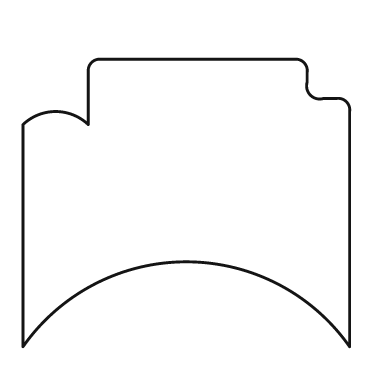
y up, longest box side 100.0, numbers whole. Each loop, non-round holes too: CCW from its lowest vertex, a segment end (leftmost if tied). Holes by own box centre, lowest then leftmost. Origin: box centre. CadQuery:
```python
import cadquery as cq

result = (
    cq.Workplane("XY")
    .moveTo(-50.0, -44.0)
    .threePointArc((0.0, -18.0), (50.0, -44.0))
    .lineTo(50.0, 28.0)
    .threePointArc((49.0, 31.0), (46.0, 32.0))
    .lineTo(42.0, 32.0)
    .threePointArc((38.0, 33.0), (37.0, 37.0))
    .lineTo(37.0, 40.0)
    .threePointArc((36.0, 43.0), (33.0, 44.0))
    .lineTo(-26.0, 44.0)
    .threePointArc((-29.0, 43.0), (-30.0, 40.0))
    .lineTo(-30.0, 24.0)
    .threePointArc((-40.0, 28.0), (-50.0, 24.0))
    .close()
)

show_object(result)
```